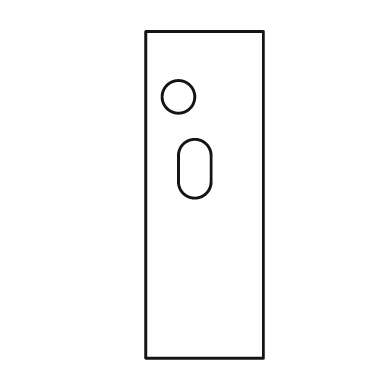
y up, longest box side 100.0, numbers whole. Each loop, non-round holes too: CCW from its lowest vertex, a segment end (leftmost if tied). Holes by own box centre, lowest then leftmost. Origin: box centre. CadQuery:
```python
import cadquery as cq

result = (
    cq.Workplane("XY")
    .moveTo(-18.0, -50.0)
    .lineTo(18.0, -50.0)
    .lineTo(18.0, 50.0)
    .lineTo(-18.0, 50.0)
    .close()
    .moveTo(-8.0, 4.0)
    .threePointArc((-3.0, -1.0), (2.0, 4.0))
    .lineTo(2.0, 12.0)
    .threePointArc((-3.0, 17.0), (-8.0, 12.0))
    .close()
    .moveTo(-8.0, 30.0)
    .circle(5.0)
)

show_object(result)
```